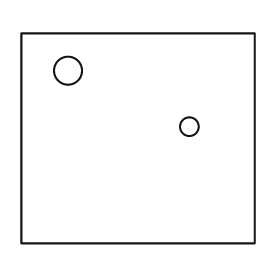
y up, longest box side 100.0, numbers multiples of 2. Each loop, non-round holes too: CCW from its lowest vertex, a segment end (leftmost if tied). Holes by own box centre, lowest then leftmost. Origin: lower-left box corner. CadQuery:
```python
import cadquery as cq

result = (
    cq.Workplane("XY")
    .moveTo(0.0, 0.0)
    .lineTo(100.0, 0.0)
    .lineTo(100.0, 90.0)
    .lineTo(0.0, 90.0)
    .close()
    .moveTo(72.0, 50.0)
    .circle(4.0)
    .moveTo(20.0, 74.0)
    .circle(6.0)
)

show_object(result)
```